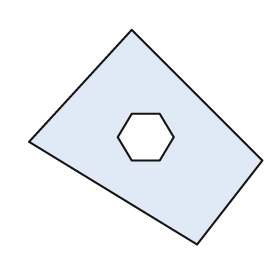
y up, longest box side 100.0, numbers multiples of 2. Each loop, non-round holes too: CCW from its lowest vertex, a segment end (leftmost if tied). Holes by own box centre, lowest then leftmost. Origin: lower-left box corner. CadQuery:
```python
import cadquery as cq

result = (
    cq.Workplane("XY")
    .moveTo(72.0, 0.0)
    .lineTo(100.0, 36.0)
    .lineTo(44.0, 92.0)
    .lineTo(0.0, 44.0)
    .close()
    .moveTo(44.0, 36.0)
    .lineTo(56.0, 36.0)
    .lineTo(62.0, 46.0)
    .lineTo(56.0, 56.0)
    .lineTo(44.0, 56.0)
    .lineTo(38.0, 46.0)
    .close()
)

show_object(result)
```